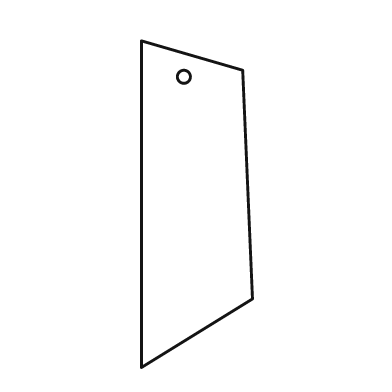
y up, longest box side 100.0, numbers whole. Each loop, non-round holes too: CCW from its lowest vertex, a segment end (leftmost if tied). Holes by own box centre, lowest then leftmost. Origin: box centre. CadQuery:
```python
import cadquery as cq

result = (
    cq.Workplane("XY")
    .moveTo(-17.0, -50.0)
    .lineTo(17.0, -29.0)
    .lineTo(14.0, 41.0)
    .lineTo(-17.0, 50.0)
    .close()
    .moveTo(-4.0, 39.0)
    .circle(2.0)
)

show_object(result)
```